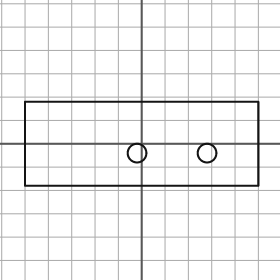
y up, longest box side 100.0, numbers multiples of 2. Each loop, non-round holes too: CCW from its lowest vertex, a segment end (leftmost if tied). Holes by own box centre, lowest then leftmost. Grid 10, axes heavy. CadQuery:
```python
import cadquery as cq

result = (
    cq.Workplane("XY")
    .moveTo(-50.0, -18.0)
    .lineTo(50.0, -18.0)
    .lineTo(50.0, 18.0)
    .lineTo(-50.0, 18.0)
    .close()
    .moveTo(-2.0, -4.0)
    .circle(4.0)
    .moveTo(28.0, -4.0)
    .circle(4.0)
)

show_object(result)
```